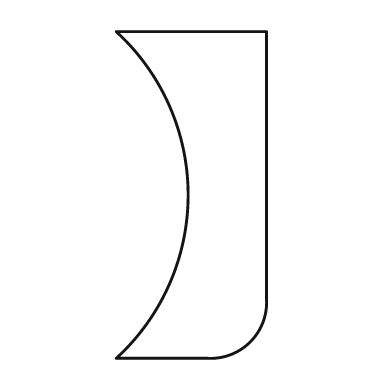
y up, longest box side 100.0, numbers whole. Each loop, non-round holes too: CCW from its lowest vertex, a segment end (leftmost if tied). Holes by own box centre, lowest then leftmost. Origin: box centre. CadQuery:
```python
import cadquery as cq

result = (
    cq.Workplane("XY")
    .moveTo(-23.0, -50.0)
    .lineTo(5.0, -50.0)
    .threePointArc((18.0, -45.0), (23.0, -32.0))
    .lineTo(23.0, 50.0)
    .lineTo(-23.0, 50.0)
    .threePointArc((-1.0, 0.0), (-23.0, -50.0))
    .close()
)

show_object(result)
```